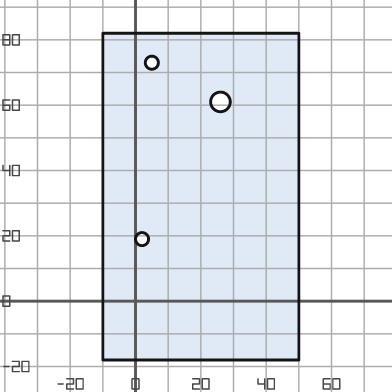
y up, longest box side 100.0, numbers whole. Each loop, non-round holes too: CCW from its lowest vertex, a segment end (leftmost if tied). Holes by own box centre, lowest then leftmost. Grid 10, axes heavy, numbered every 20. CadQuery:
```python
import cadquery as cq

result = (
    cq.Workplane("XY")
    .moveTo(-10.0, -18.0)
    .lineTo(50.0, -18.0)
    .lineTo(50.0, 82.0)
    .lineTo(-10.0, 82.0)
    .close()
    .moveTo(2.0, 19.0)
    .circle(2.0)
    .moveTo(26.0, 61.0)
    .circle(3.0)
    .moveTo(5.0, 73.0)
    .circle(2.0)
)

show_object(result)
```